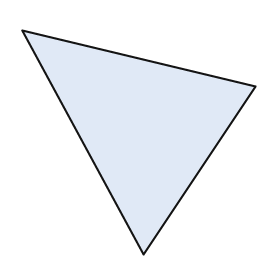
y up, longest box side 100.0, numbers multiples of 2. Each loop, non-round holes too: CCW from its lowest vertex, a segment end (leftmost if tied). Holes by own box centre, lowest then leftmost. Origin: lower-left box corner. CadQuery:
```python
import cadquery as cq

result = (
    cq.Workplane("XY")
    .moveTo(52.0, 0.0)
    .lineTo(100.0, 72.0)
    .lineTo(0.0, 96.0)
    .close()
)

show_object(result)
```